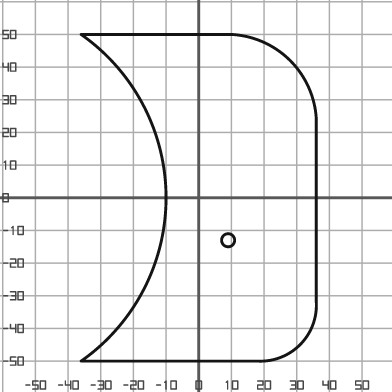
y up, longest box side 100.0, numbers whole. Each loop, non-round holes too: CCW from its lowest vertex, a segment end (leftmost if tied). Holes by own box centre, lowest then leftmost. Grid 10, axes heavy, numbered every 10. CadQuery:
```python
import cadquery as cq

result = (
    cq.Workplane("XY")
    .moveTo(-36.0, -50.0)
    .lineTo(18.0, -50.0)
    .threePointArc((31.0, -45.0), (36.0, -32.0))
    .lineTo(36.0, 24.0)
    .threePointArc((28.0, 42.0), (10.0, 50.0))
    .lineTo(-36.0, 50.0)
    .threePointArc((-10.0, 0.0), (-36.0, -50.0))
    .close()
    .moveTo(9.0, -13.0)
    .circle(2.0)
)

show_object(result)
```